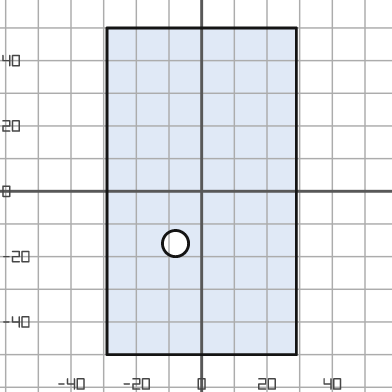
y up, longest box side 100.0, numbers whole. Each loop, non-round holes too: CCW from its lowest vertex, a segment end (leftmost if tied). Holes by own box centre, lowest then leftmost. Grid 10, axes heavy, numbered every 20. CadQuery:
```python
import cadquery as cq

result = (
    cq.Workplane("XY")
    .moveTo(-29.0, -50.0)
    .lineTo(29.0, -50.0)
    .lineTo(29.0, 50.0)
    .lineTo(-29.0, 50.0)
    .close()
    .moveTo(-8.0, -16.0)
    .circle(4.0)
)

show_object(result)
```